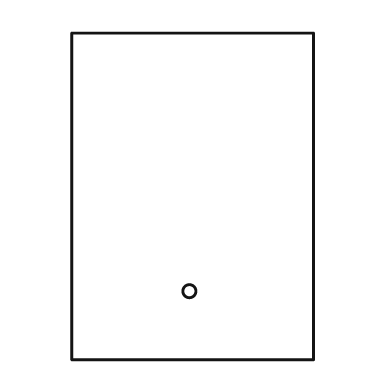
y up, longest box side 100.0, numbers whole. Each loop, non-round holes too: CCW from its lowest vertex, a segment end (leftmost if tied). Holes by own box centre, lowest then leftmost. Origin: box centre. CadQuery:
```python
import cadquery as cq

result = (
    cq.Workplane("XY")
    .moveTo(-37.0, -50.0)
    .lineTo(37.0, -50.0)
    .lineTo(37.0, 50.0)
    .lineTo(-37.0, 50.0)
    .close()
    .moveTo(-1.0, -29.0)
    .circle(2.0)
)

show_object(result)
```